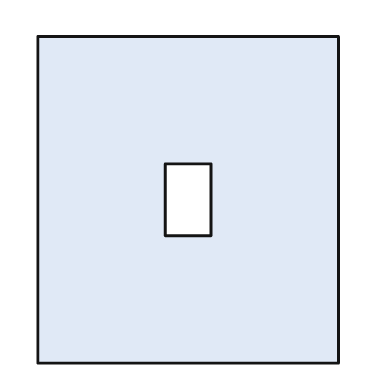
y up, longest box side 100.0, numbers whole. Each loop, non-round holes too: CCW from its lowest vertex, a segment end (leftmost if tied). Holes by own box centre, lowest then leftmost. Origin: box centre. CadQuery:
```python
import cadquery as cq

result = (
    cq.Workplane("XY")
    .moveTo(-46.0, -50.0)
    .lineTo(46.0, -50.0)
    .lineTo(46.0, 50.0)
    .lineTo(-46.0, 50.0)
    .close()
    .moveTo(-7.0, -11.0)
    .lineTo(7.0, -11.0)
    .lineTo(7.0, 11.0)
    .lineTo(-7.0, 11.0)
    .close()
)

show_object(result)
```